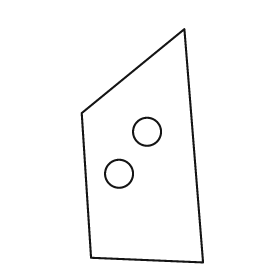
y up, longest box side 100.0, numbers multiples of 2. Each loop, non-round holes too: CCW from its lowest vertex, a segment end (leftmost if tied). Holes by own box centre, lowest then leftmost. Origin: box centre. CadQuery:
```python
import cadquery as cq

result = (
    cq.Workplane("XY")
    .moveTo(26.0, -50.0)
    .lineTo(18.0, 50.0)
    .lineTo(-26.0, 14.0)
    .lineTo(-22.0, -48.0)
    .close()
    .moveTo(-10.0, -12.0)
    .circle(6.0)
    .moveTo(2.0, 6.0)
    .circle(6.0)
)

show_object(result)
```